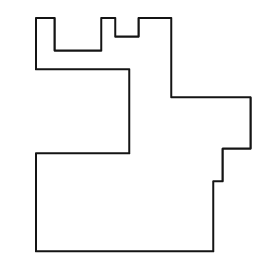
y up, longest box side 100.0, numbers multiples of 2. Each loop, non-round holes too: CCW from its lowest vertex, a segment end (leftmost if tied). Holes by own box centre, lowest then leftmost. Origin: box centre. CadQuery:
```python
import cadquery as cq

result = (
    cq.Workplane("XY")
    .moveTo(-46.0, -50.0)
    .lineTo(30.0, -50.0)
    .lineTo(30.0, -20.0)
    .lineTo(34.0, -20.0)
    .lineTo(34.0, -6.0)
    .lineTo(46.0, -6.0)
    .lineTo(46.0, 16.0)
    .lineTo(12.0, 16.0)
    .lineTo(12.0, 50.0)
    .lineTo(-2.0, 50.0)
    .lineTo(-2.0, 42.0)
    .lineTo(-12.0, 42.0)
    .lineTo(-12.0, 50.0)
    .lineTo(-18.0, 50.0)
    .lineTo(-18.0, 36.0)
    .lineTo(-38.0, 36.0)
    .lineTo(-38.0, 50.0)
    .lineTo(-46.0, 50.0)
    .lineTo(-46.0, 28.0)
    .lineTo(-6.0, 28.0)
    .lineTo(-6.0, -8.0)
    .lineTo(-46.0, -8.0)
    .close()
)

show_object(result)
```